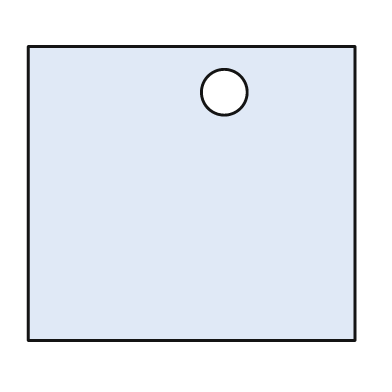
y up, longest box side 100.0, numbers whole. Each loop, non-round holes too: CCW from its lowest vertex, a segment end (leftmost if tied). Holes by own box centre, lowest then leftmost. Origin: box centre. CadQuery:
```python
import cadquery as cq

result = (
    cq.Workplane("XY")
    .moveTo(-50.0, -45.0)
    .lineTo(50.0, -45.0)
    .lineTo(50.0, 45.0)
    .lineTo(-50.0, 45.0)
    .close()
    .moveTo(10.0, 31.0)
    .circle(7.0)
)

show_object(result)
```